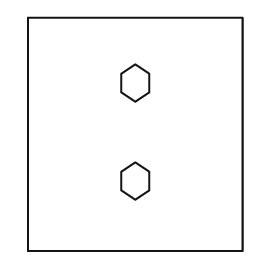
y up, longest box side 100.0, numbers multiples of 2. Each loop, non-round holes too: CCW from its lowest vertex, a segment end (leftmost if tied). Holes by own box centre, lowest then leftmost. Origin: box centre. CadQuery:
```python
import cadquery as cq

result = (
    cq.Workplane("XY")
    .moveTo(-46.0, -50.0)
    .lineTo(46.0, -50.0)
    .lineTo(46.0, 50.0)
    .lineTo(-46.0, 50.0)
    .close()
    .moveTo(0.0, -28.0)
    .lineTo(6.0, -24.0)
    .lineTo(6.0, -16.0)
    .lineTo(0.0, -12.0)
    .lineTo(-6.0, -16.0)
    .lineTo(-6.0, -24.0)
    .close()
    .moveTo(0.0, 14.0)
    .lineTo(6.0, 18.0)
    .lineTo(6.0, 26.0)
    .lineTo(0.0, 30.0)
    .lineTo(-6.0, 26.0)
    .lineTo(-6.0, 18.0)
    .close()
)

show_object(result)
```